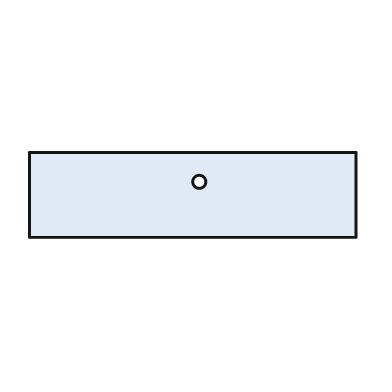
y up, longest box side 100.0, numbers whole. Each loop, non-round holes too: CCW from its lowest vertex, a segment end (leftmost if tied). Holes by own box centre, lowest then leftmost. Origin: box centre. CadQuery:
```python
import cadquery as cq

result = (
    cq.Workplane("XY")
    .moveTo(-50.0, -13.0)
    .lineTo(50.0, -13.0)
    .lineTo(50.0, 13.0)
    .lineTo(-50.0, 13.0)
    .close()
    .moveTo(2.0, 4.0)
    .circle(2.0)
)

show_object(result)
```